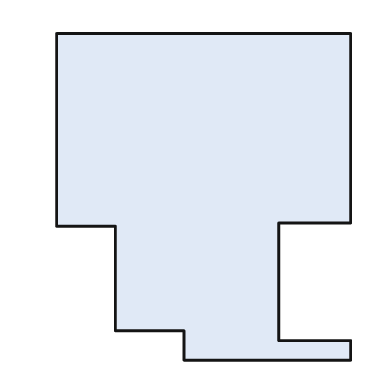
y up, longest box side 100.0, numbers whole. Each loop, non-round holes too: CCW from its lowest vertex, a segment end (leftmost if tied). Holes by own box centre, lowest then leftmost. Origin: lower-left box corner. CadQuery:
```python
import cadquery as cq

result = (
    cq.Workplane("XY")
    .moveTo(39.0, 0.0)
    .lineTo(90.0, 0.0)
    .lineTo(90.0, 6.0)
    .lineTo(68.0, 6.0)
    .lineTo(68.0, 42.0)
    .lineTo(90.0, 42.0)
    .lineTo(90.0, 100.0)
    .lineTo(0.0, 100.0)
    .lineTo(0.0, 41.0)
    .lineTo(18.0, 41.0)
    .lineTo(18.0, 9.0)
    .lineTo(39.0, 9.0)
    .close()
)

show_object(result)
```